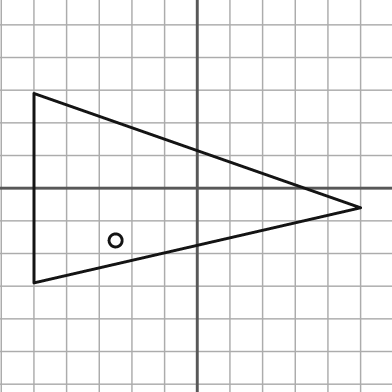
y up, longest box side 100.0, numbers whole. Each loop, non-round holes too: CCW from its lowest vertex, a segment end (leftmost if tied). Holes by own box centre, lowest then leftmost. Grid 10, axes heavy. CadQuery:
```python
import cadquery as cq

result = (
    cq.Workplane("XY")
    .moveTo(-50.0, -29.0)
    .lineTo(50.0, -6.0)
    .lineTo(-50.0, 29.0)
    .close()
    .moveTo(-25.0, -16.0)
    .circle(2.0)
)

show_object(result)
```